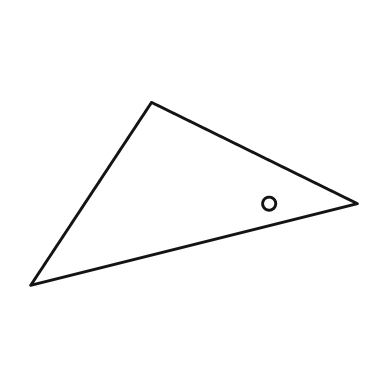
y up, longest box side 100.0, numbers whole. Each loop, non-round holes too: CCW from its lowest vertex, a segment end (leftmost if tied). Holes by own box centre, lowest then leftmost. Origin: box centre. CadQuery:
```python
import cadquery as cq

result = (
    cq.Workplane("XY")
    .moveTo(-50.0, -28.0)
    .lineTo(50.0, -3.0)
    .lineTo(-13.0, 28.0)
    .close()
    .moveTo(23.0, -3.0)
    .circle(2.0)
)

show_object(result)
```